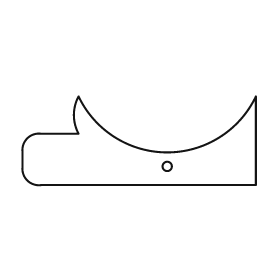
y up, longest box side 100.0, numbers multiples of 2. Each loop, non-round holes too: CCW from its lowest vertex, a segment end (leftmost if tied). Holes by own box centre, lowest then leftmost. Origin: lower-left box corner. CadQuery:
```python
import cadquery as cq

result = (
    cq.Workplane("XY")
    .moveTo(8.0, 0.0)
    .lineTo(100.0, 0.0)
    .lineTo(100.0, 38.0)
    .threePointArc((62.0, 14.0), (24.0, 38.0))
    .threePointArc((22.0, 30.0), (24.0, 22.0))
    .lineTo(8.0, 22.0)
    .threePointArc((2.0, 20.0), (0.0, 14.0))
    .lineTo(0.0, 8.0)
    .threePointArc((2.0, 2.0), (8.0, 0.0))
    .close()
    .moveTo(62.0, 8.0)
    .circle(2.0)
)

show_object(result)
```